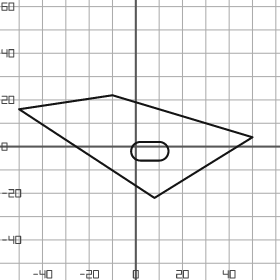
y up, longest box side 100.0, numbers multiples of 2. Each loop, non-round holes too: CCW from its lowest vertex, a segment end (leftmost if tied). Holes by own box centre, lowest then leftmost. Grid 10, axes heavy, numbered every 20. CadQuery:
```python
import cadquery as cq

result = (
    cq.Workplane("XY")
    .moveTo(8.0, -22.0)
    .lineTo(50.0, 4.0)
    .lineTo(-10.0, 22.0)
    .lineTo(-50.0, 16.0)
    .close()
    .moveTo(2.0, -6.0)
    .lineTo(10.0, -6.0)
    .threePointArc((14.0, -2.0), (10.0, 2.0))
    .lineTo(2.0, 2.0)
    .threePointArc((-2.0, -2.0), (2.0, -6.0))
    .close()
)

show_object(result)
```